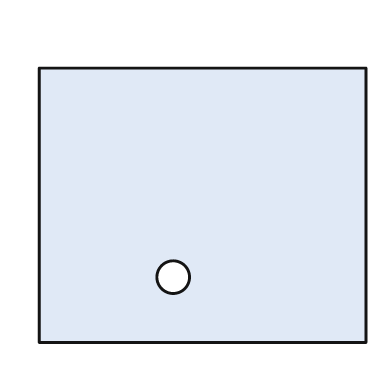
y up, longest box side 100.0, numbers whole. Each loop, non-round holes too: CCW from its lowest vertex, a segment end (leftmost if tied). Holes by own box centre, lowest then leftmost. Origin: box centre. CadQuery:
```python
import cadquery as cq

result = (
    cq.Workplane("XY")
    .moveTo(-50.0, -42.0)
    .lineTo(50.0, -42.0)
    .lineTo(50.0, 42.0)
    .lineTo(-50.0, 42.0)
    .close()
    .moveTo(-9.0, -22.0)
    .circle(5.0)
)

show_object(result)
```